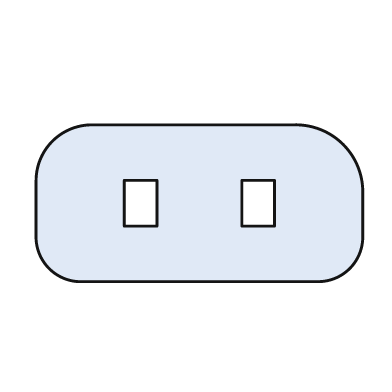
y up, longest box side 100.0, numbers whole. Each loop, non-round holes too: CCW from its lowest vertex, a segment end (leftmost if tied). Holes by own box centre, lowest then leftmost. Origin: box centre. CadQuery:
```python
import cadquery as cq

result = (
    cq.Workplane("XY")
    .moveTo(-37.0, -24.0)
    .lineTo(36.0, -24.0)
    .threePointArc((46.0, -20.0), (50.0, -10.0))
    .lineTo(50.0, 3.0)
    .threePointArc((44.0, 18.0), (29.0, 24.0))
    .lineTo(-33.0, 24.0)
    .threePointArc((-45.0, 19.0), (-50.0, 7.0))
    .lineTo(-50.0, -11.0)
    .threePointArc((-46.0, -20.0), (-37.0, -24.0))
    .close()
    .moveTo(-23.0, -7.0)
    .lineTo(-13.0, -7.0)
    .lineTo(-13.0, 7.0)
    .lineTo(-23.0, 7.0)
    .close()
    .moveTo(13.0, -7.0)
    .lineTo(23.0, -7.0)
    .lineTo(23.0, 7.0)
    .lineTo(13.0, 7.0)
    .close()
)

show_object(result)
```